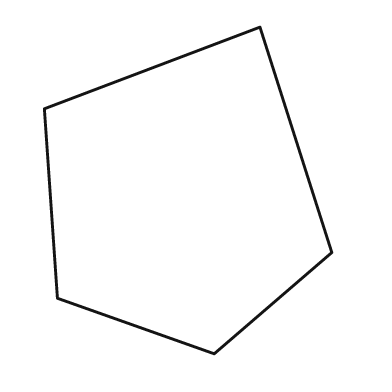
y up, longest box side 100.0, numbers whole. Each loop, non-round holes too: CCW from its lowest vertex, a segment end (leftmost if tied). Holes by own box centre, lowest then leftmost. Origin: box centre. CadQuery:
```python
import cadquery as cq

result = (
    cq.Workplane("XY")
    .moveTo(8.0, -50.0)
    .lineTo(44.0, -19.0)
    .lineTo(22.0, 50.0)
    .lineTo(-44.0, 25.0)
    .lineTo(-40.0, -33.0)
    .close()
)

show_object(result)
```